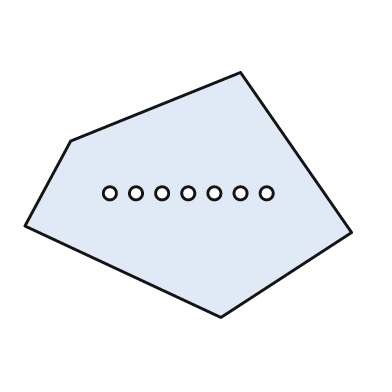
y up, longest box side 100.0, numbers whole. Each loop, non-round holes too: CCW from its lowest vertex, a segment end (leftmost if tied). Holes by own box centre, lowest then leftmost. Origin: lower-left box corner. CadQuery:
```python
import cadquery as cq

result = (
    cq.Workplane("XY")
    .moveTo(60.0, 0.0)
    .lineTo(100.0, 26.0)
    .lineTo(66.0, 75.0)
    .lineTo(14.0, 54.0)
    .lineTo(0.0, 28.0)
    .close()
    .moveTo(26.0, 38.0)
    .circle(2.0)
    .moveTo(34.0, 38.0)
    .circle(2.0)
    .moveTo(42.0, 38.0)
    .circle(2.0)
    .moveTo(50.0, 38.0)
    .circle(2.0)
    .moveTo(58.0, 38.0)
    .circle(2.0)
    .moveTo(66.0, 38.0)
    .circle(2.0)
    .moveTo(74.0, 38.0)
    .circle(2.0)
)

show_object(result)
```